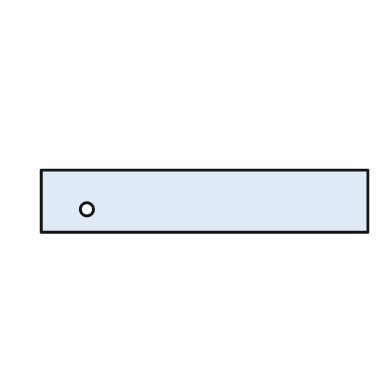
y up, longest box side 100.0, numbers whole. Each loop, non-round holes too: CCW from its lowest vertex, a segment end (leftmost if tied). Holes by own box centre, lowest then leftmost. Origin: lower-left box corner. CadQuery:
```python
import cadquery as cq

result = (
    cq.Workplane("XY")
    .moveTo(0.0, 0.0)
    .lineTo(100.0, 0.0)
    .lineTo(100.0, 19.0)
    .lineTo(0.0, 19.0)
    .close()
    .moveTo(14.0, 7.0)
    .circle(2.0)
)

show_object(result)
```